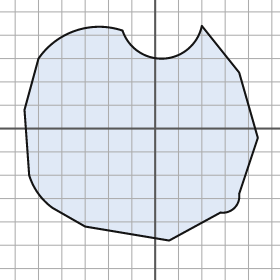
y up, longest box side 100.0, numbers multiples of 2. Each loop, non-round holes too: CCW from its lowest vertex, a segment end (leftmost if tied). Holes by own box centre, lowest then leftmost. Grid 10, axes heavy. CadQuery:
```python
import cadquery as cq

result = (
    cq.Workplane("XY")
    .moveTo(6.0, -48.0)
    .lineTo(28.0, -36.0)
    .threePointArc((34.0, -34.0), (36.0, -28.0))
    .lineTo(44.0, -4.0)
    .lineTo(36.0, 24.0)
    .lineTo(20.0, 44.0)
    .threePointArc((4.0, 30.0), (-14.0, 42.0))
    .threePointArc((-34.0, 42.0), (-50.0, 30.0))
    .lineTo(-56.0, 8.0)
    .lineTo(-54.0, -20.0)
    .threePointArc((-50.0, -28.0), (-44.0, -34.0))
    .lineTo(-30.0, -42.0)
    .close()
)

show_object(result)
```